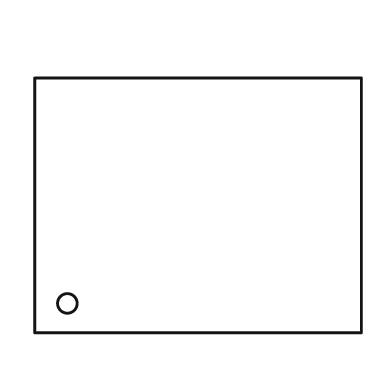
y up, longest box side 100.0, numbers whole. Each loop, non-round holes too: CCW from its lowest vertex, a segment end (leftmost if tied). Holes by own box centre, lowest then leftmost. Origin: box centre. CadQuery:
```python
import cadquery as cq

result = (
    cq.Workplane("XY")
    .moveTo(-50.0, -39.0)
    .lineTo(50.0, -39.0)
    .lineTo(50.0, 39.0)
    .lineTo(-50.0, 39.0)
    .close()
    .moveTo(-40.0, -30.0)
    .circle(3.0)
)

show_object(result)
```